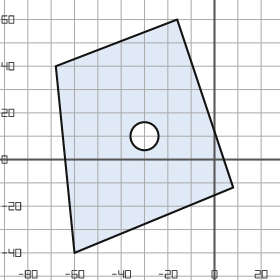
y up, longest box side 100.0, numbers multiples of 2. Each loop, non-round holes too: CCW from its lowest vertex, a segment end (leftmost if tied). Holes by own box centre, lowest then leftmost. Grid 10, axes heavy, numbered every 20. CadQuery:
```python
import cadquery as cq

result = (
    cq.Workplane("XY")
    .moveTo(-60.0, -40.0)
    .lineTo(8.0, -12.0)
    .lineTo(-16.0, 60.0)
    .lineTo(-68.0, 40.0)
    .close()
    .moveTo(-30.0, 10.0)
    .circle(6.0)
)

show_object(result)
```